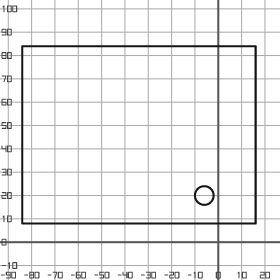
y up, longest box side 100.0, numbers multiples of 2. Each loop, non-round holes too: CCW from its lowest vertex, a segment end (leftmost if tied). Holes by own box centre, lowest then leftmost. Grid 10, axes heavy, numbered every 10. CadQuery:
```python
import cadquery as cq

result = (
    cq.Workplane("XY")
    .moveTo(-84.0, 8.0)
    .lineTo(16.0, 8.0)
    .lineTo(16.0, 84.0)
    .lineTo(-84.0, 84.0)
    .close()
    .moveTo(-6.0, 20.0)
    .circle(4.0)
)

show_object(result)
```